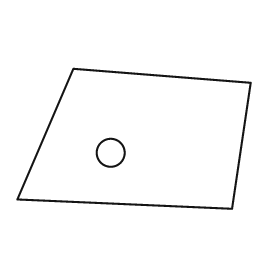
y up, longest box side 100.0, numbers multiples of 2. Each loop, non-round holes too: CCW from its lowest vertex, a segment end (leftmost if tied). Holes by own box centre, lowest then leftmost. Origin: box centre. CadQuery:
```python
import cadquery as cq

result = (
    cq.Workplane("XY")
    .moveTo(42.0, -30.0)
    .lineTo(50.0, 24.0)
    .lineTo(-26.0, 30.0)
    .lineTo(-50.0, -26.0)
    .close()
    .moveTo(-10.0, -6.0)
    .circle(6.0)
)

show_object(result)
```